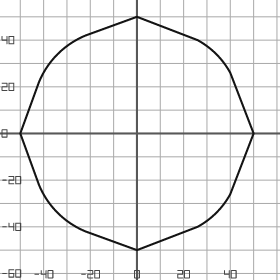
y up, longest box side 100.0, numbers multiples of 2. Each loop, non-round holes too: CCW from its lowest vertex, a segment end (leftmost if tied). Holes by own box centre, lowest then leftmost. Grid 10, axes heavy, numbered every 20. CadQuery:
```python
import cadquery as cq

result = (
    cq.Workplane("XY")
    .moveTo(0.0, -50.0)
    .lineTo(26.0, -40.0)
    .threePointArc((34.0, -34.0), (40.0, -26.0))
    .lineTo(50.0, 0.0)
    .lineTo(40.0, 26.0)
    .threePointArc((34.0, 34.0), (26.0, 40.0))
    .lineTo(0.0, 50.0)
    .lineTo(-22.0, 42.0)
    .threePointArc((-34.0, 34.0), (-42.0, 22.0))
    .lineTo(-50.0, 0.0)
    .lineTo(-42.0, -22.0)
    .threePointArc((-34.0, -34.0), (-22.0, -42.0))
    .close()
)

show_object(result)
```